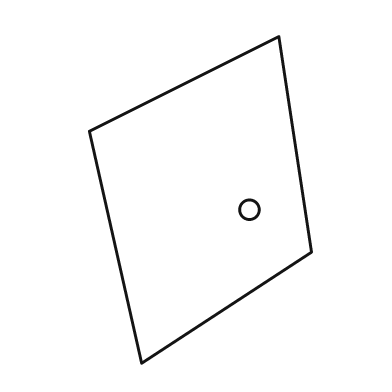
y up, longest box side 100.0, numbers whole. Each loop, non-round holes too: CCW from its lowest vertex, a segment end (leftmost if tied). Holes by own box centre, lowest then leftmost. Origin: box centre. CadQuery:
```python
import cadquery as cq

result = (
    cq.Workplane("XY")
    .moveTo(-18.0, -50.0)
    .lineTo(34.0, -16.0)
    .lineTo(24.0, 50.0)
    .lineTo(-34.0, 21.0)
    .close()
    .moveTo(15.0, -3.0)
    .circle(3.0)
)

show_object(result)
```